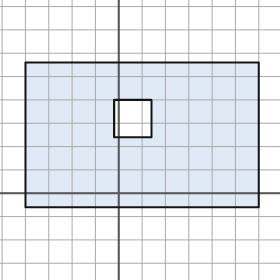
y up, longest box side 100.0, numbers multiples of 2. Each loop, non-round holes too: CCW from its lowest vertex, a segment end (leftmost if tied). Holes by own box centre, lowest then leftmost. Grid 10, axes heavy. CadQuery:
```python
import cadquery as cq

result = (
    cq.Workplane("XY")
    .moveTo(-40.0, -6.0)
    .lineTo(60.0, -6.0)
    .lineTo(60.0, 56.0)
    .lineTo(-40.0, 56.0)
    .close()
    .moveTo(-2.0, 24.0)
    .lineTo(14.0, 24.0)
    .lineTo(14.0, 40.0)
    .lineTo(-2.0, 40.0)
    .close()
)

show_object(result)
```